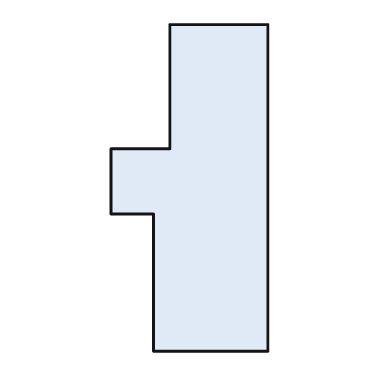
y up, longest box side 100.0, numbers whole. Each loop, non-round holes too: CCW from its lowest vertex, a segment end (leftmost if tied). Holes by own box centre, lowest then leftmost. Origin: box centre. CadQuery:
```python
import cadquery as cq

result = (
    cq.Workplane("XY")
    .moveTo(-11.0, -50.0)
    .lineTo(24.0, -50.0)
    .lineTo(24.0, 50.0)
    .lineTo(-6.0, 50.0)
    .lineTo(-6.0, 12.0)
    .lineTo(-24.0, 12.0)
    .lineTo(-24.0, -8.0)
    .lineTo(-11.0, -8.0)
    .close()
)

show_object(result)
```